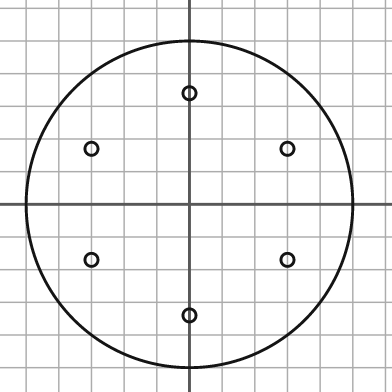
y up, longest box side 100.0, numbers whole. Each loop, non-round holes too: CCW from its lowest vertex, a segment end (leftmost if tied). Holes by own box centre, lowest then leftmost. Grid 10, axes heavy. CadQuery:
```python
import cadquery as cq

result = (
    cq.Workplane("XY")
    .moveTo(0.0, 0.0)
    .circle(50.0)
    .moveTo(0.0, -34.0)
    .circle(2.0)
    .moveTo(-30.0, -17.0)
    .circle(2.0)
    .moveTo(30.0, -17.0)
    .circle(2.0)
    .moveTo(-30.0, 17.0)
    .circle(2.0)
    .moveTo(30.0, 17.0)
    .circle(2.0)
    .moveTo(0.0, 34.0)
    .circle(2.0)
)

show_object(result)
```